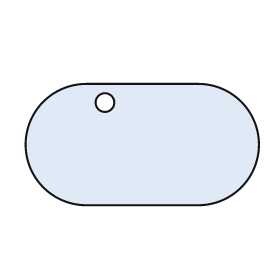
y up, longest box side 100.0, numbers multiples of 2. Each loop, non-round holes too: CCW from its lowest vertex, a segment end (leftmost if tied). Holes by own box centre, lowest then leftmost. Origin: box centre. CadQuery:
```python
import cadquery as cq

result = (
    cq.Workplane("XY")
    .moveTo(-24.0, -26.0)
    .lineTo(24.0, -26.0)
    .threePointArc((50.0, 0.0), (24.0, 26.0))
    .lineTo(-24.0, 26.0)
    .threePointArc((-50.0, 0.0), (-24.0, -26.0))
    .close()
    .moveTo(-16.0, 18.0)
    .circle(4.0)
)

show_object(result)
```